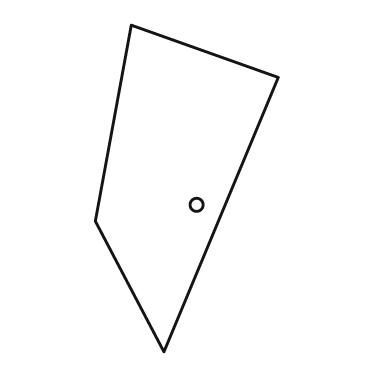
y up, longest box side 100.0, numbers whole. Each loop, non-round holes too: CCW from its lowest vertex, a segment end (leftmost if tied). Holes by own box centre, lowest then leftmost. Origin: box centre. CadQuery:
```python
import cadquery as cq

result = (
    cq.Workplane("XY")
    .moveTo(-7.0, -50.0)
    .lineTo(28.0, 34.0)
    .lineTo(-17.0, 50.0)
    .lineTo(-28.0, -10.0)
    .close()
    .moveTo(3.0, -5.0)
    .circle(2.0)
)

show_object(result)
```